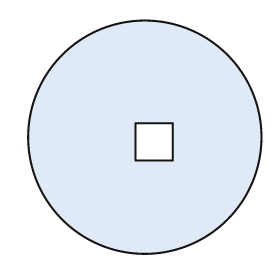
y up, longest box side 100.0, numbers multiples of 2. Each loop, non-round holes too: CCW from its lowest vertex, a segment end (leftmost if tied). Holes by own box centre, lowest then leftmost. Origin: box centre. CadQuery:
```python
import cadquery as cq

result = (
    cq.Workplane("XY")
    .moveTo(0.0, 0.0)
    .circle(50.0)
    .moveTo(-4.0, -10.0)
    .lineTo(12.0, -10.0)
    .lineTo(12.0, 6.0)
    .lineTo(-4.0, 6.0)
    .close()
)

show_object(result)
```